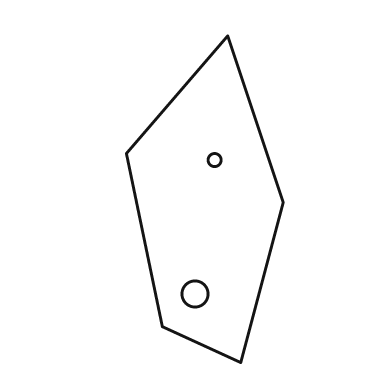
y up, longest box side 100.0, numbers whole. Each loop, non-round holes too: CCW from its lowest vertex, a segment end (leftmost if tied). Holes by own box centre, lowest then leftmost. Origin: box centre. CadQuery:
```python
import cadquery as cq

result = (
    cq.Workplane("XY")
    .moveTo(11.0, -50.0)
    .lineTo(24.0, -1.0)
    .lineTo(7.0, 50.0)
    .lineTo(-24.0, 14.0)
    .lineTo(-13.0, -39.0)
    .close()
    .moveTo(-3.0, -29.0)
    .circle(4.0)
    .moveTo(3.0, 12.0)
    .circle(2.0)
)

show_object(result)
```